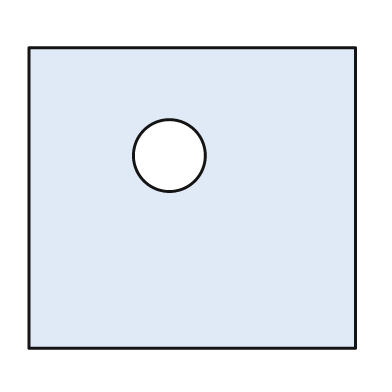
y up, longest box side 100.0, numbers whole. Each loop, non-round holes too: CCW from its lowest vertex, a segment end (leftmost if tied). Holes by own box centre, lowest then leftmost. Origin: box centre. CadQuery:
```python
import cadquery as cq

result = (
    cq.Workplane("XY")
    .moveTo(-50.0, -46.0)
    .lineTo(50.0, -46.0)
    .lineTo(50.0, 46.0)
    .lineTo(-50.0, 46.0)
    .close()
    .moveTo(-7.0, 13.0)
    .circle(11.0)
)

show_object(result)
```